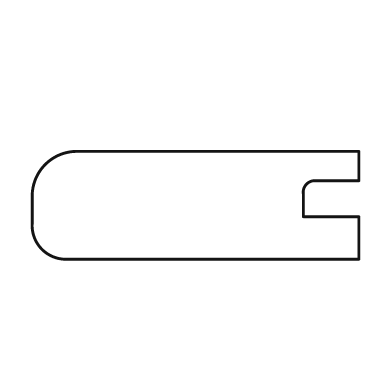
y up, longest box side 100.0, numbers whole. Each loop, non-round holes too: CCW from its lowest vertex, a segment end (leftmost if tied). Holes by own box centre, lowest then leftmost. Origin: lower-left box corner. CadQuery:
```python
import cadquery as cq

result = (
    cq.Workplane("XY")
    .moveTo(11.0, 0.0)
    .lineTo(100.0, 0.0)
    .lineTo(100.0, 13.0)
    .lineTo(83.0, 13.0)
    .lineTo(83.0, 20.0)
    .threePointArc((84.0, 23.0), (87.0, 24.0))
    .lineTo(100.0, 24.0)
    .lineTo(100.0, 33.0)
    .lineTo(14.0, 33.0)
    .threePointArc((4.0, 29.0), (0.0, 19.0))
    .lineTo(0.0, 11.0)
    .threePointArc((3.0, 3.0), (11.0, 0.0))
    .close()
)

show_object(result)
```